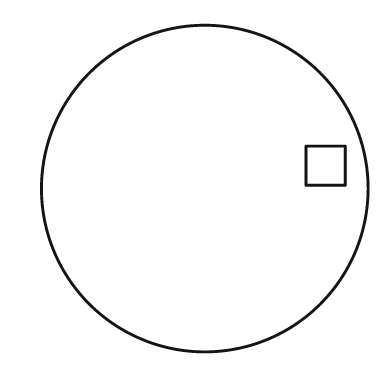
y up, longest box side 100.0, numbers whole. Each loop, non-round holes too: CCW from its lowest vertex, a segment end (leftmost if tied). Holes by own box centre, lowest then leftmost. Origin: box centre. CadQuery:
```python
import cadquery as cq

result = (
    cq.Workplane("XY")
    .moveTo(0.0, 0.0)
    .circle(50.0)
    .moveTo(31.0, 1.0)
    .lineTo(43.0, 1.0)
    .lineTo(43.0, 13.0)
    .lineTo(31.0, 13.0)
    .close()
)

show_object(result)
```